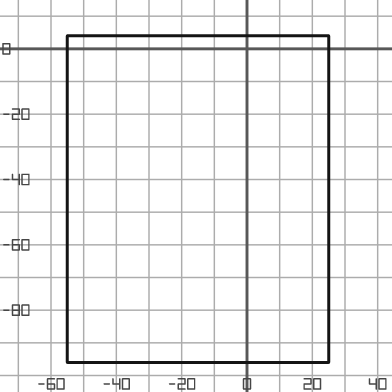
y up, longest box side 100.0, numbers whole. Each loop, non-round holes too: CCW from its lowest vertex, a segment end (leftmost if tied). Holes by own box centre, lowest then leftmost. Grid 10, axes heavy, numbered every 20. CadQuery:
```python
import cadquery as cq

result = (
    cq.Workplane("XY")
    .moveTo(-55.0, -96.0)
    .lineTo(25.0, -96.0)
    .lineTo(25.0, 4.0)
    .lineTo(-55.0, 4.0)
    .close()
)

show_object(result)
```